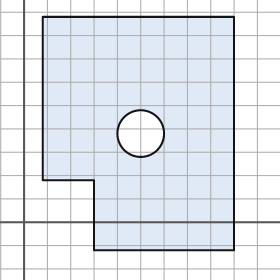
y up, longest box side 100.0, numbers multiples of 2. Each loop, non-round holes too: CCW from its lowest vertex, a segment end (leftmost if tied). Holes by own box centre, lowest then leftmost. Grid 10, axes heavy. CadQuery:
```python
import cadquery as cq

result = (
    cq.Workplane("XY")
    .moveTo(30.0, -12.0)
    .lineTo(90.0, -12.0)
    .lineTo(90.0, 88.0)
    .lineTo(8.0, 88.0)
    .lineTo(8.0, 18.0)
    .lineTo(30.0, 18.0)
    .close()
    .moveTo(50.0, 38.0)
    .circle(10.0)
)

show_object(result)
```